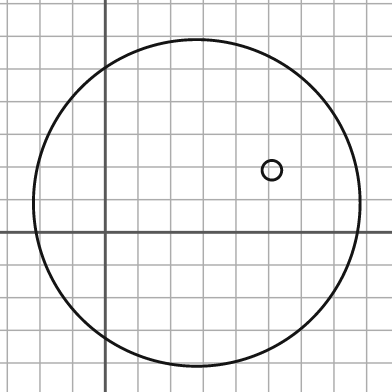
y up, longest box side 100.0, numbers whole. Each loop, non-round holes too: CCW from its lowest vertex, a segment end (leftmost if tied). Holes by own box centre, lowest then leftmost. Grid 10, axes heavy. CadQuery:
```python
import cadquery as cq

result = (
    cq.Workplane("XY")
    .moveTo(28.0, 9.0)
    .circle(50.0)
    .moveTo(51.0, 19.0)
    .circle(3.0)
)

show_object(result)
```